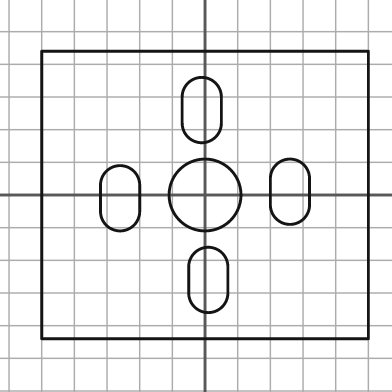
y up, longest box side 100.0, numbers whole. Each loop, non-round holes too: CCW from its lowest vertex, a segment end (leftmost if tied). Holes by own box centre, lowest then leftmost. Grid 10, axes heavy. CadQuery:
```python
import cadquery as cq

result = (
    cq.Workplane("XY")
    .moveTo(-50.0, -44.0)
    .lineTo(50.0, -44.0)
    .lineTo(50.0, 44.0)
    .lineTo(-50.0, 44.0)
    .close()
    .moveTo(-5.0, -30.0)
    .threePointArc((1.0, -36.0), (7.0, -30.0))
    .lineTo(7.0, -22.0)
    .threePointArc((1.0, -16.0), (-5.0, -22.0))
    .close()
    .moveTo(-32.0, -5.0)
    .threePointArc((-26.0, -11.0), (-20.0, -5.0))
    .lineTo(-20.0, 3.0)
    .threePointArc((-26.0, 9.0), (-32.0, 3.0))
    .close()
    .moveTo(0.0, 0.0)
    .circle(11.0)
    .moveTo(20.0, -3.0)
    .threePointArc((26.0, -9.0), (32.0, -3.0))
    .lineTo(32.0, 5.0)
    .threePointArc((26.0, 11.0), (20.0, 5.0))
    .close()
    .moveTo(-7.0, 22.0)
    .threePointArc((-1.0, 16.0), (5.0, 22.0))
    .lineTo(5.0, 30.0)
    .threePointArc((-1.0, 36.0), (-7.0, 30.0))
    .close()
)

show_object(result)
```